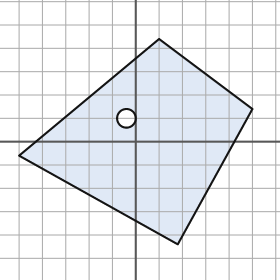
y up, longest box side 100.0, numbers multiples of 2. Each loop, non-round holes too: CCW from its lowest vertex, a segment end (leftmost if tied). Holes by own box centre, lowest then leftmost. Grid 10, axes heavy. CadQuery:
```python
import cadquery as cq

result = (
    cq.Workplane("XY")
    .moveTo(18.0, -44.0)
    .lineTo(50.0, 14.0)
    .lineTo(10.0, 44.0)
    .lineTo(-50.0, -6.0)
    .close()
    .moveTo(-4.0, 10.0)
    .circle(4.0)
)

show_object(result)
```